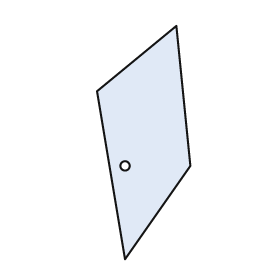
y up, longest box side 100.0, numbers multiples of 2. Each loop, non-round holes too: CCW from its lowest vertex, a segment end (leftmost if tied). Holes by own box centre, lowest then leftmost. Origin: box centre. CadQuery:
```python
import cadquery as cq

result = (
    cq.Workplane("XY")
    .moveTo(-8.0, -50.0)
    .lineTo(20.0, -10.0)
    .lineTo(14.0, 50.0)
    .lineTo(-20.0, 22.0)
    .close()
    .moveTo(-8.0, -10.0)
    .circle(2.0)
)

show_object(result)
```